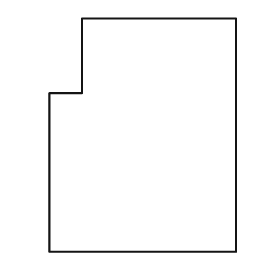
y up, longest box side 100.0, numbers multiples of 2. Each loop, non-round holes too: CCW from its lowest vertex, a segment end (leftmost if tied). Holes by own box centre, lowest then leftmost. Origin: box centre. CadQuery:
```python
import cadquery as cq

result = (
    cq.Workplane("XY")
    .moveTo(-40.0, -50.0)
    .lineTo(40.0, -50.0)
    .lineTo(40.0, 50.0)
    .lineTo(-26.0, 50.0)
    .lineTo(-26.0, 18.0)
    .lineTo(-40.0, 18.0)
    .close()
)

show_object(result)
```